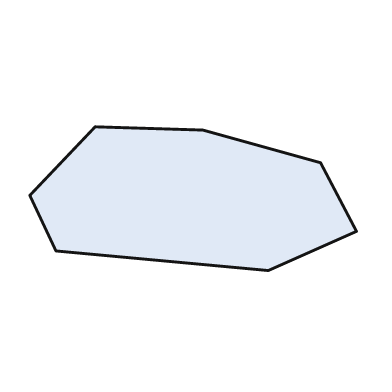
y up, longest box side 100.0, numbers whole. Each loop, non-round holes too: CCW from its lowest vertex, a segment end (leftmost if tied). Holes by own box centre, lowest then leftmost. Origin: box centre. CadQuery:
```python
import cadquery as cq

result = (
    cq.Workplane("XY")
    .moveTo(23.0, -22.0)
    .lineTo(50.0, -10.0)
    .lineTo(39.0, 11.0)
    .lineTo(3.0, 21.0)
    .lineTo(-30.0, 22.0)
    .lineTo(-50.0, 1.0)
    .lineTo(-42.0, -16.0)
    .close()
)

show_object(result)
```